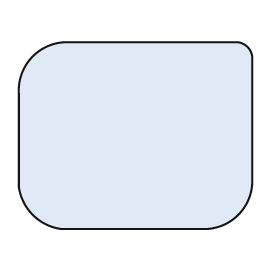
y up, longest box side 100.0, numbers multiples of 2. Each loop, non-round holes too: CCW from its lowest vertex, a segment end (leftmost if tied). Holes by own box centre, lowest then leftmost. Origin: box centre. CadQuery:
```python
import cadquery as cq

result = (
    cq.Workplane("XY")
    .moveTo(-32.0, -40.0)
    .lineTo(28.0, -40.0)
    .threePointArc((44.0, -34.0), (50.0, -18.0))
    .lineTo(50.0, 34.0)
    .threePointArc((48.0, 38.0), (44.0, 40.0))
    .lineTo(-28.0, 40.0)
    .threePointArc((-44.0, 34.0), (-50.0, 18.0))
    .lineTo(-50.0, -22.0)
    .threePointArc((-44.0, -34.0), (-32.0, -40.0))
    .close()
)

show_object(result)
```